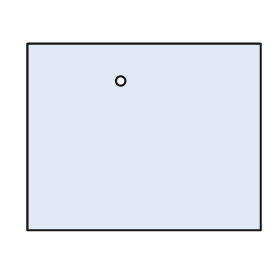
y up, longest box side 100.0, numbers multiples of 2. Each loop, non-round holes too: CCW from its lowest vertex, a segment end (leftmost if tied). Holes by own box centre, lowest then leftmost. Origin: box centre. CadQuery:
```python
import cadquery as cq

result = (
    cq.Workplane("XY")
    .moveTo(-50.0, -40.0)
    .lineTo(50.0, -40.0)
    .lineTo(50.0, 40.0)
    .lineTo(-50.0, 40.0)
    .close()
    .moveTo(-10.0, 24.0)
    .circle(2.0)
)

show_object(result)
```